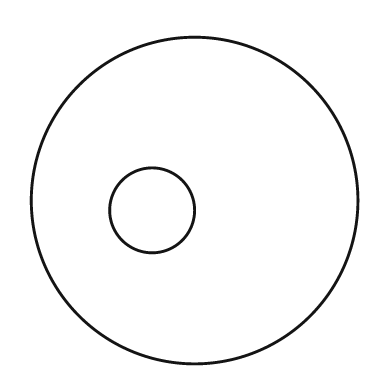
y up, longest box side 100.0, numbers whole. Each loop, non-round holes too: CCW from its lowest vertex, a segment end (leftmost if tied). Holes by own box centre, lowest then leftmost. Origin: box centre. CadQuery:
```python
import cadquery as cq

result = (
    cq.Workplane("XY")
    .moveTo(0.0, 0.0)
    .circle(50.0)
    .moveTo(-13.0, -3.0)
    .circle(13.0)
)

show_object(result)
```